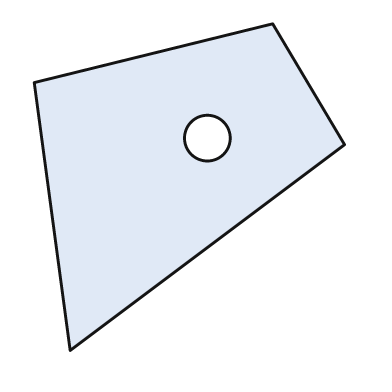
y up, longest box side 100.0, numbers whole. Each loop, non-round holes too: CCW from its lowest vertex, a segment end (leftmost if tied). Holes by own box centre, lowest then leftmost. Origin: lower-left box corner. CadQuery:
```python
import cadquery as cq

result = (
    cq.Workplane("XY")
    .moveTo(11.0, 0.0)
    .lineTo(95.0, 63.0)
    .lineTo(73.0, 100.0)
    .lineTo(0.0, 82.0)
    .close()
    .moveTo(53.0, 65.0)
    .circle(7.0)
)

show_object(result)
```